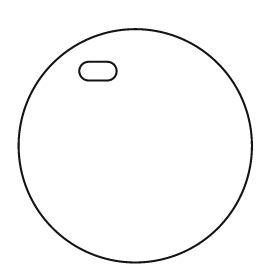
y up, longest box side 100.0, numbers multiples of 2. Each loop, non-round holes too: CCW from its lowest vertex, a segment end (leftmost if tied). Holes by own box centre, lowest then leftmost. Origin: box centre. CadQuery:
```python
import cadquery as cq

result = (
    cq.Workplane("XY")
    .moveTo(0.0, 0.0)
    .circle(50.0)
    .moveTo(-20.0, 28.0)
    .lineTo(-12.0, 28.0)
    .threePointArc((-8.0, 32.0), (-12.0, 36.0))
    .lineTo(-20.0, 36.0)
    .threePointArc((-24.0, 32.0), (-20.0, 28.0))
    .close()
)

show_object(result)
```